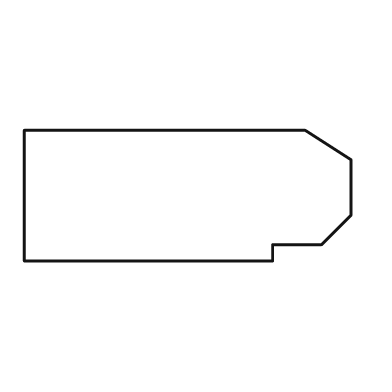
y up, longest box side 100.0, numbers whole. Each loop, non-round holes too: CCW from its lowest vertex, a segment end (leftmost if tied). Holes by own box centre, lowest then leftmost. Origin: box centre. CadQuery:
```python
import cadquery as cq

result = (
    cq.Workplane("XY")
    .moveTo(-50.0, -20.0)
    .lineTo(26.0, -20.0)
    .lineTo(26.0, -15.0)
    .lineTo(41.0, -15.0)
    .lineTo(50.0, -6.0)
    .lineTo(50.0, 11.0)
    .lineTo(36.0, 20.0)
    .lineTo(-50.0, 20.0)
    .close()
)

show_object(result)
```